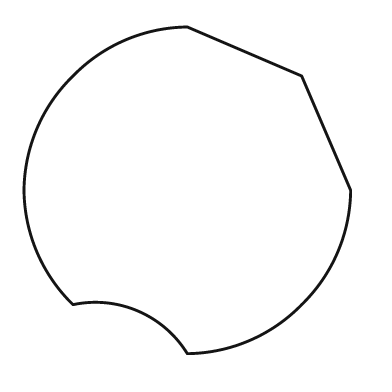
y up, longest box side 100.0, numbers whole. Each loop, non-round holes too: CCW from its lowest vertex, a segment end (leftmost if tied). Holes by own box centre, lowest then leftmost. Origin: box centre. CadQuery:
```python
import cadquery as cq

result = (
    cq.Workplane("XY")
    .moveTo(0.0, -50.0)
    .threePointArc((19.0, -46.0), (35.0, -35.0))
    .threePointArc((46.0, -19.0), (50.0, 0.0))
    .lineTo(35.0, 35.0)
    .lineTo(0.0, 50.0)
    .threePointArc((-19.0, 46.0), (-35.0, 35.0))
    .threePointArc((-46.0, 19.0), (-50.0, 0.0))
    .threePointArc((-46.0, -19.0), (-35.0, -35.0))
    .threePointArc((-15.0, -37.0), (0.0, -50.0))
    .close()
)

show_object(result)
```